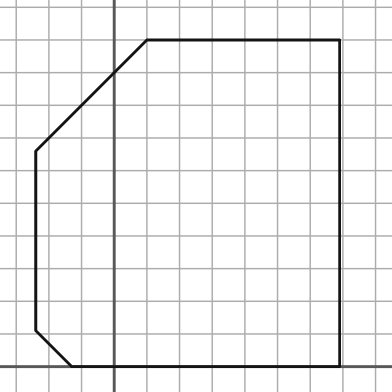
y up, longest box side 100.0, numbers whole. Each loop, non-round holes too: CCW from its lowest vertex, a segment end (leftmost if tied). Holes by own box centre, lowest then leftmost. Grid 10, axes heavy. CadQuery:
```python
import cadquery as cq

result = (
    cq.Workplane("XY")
    .moveTo(-13.0, 0.0)
    .lineTo(69.0, 0.0)
    .lineTo(69.0, 100.0)
    .lineTo(10.0, 100.0)
    .lineTo(-24.0, 66.0)
    .lineTo(-24.0, 11.0)
    .close()
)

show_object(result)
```